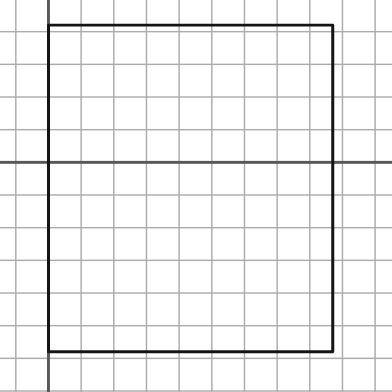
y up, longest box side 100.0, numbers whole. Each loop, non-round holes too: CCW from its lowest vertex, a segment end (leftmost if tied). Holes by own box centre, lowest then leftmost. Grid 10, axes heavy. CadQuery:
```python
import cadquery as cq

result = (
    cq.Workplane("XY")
    .moveTo(0.0, -58.0)
    .lineTo(87.0, -58.0)
    .lineTo(87.0, 42.0)
    .lineTo(0.0, 42.0)
    .close()
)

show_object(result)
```